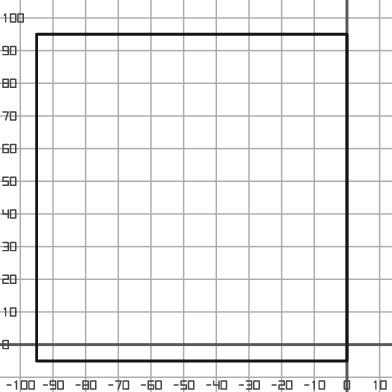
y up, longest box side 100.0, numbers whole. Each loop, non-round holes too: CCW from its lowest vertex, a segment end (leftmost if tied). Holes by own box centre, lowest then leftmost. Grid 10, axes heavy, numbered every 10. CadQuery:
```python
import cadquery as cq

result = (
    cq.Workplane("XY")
    .moveTo(-95.0, -5.0)
    .lineTo(0.0, -5.0)
    .lineTo(0.0, 95.0)
    .lineTo(-95.0, 95.0)
    .close()
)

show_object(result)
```